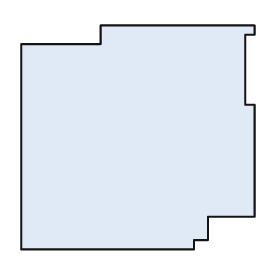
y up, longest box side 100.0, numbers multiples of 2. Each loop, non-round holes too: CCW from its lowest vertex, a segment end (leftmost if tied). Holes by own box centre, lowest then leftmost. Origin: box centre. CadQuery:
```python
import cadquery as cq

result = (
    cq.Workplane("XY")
    .moveTo(-50.0, -48.0)
    .lineTo(24.0, -48.0)
    .lineTo(24.0, -44.0)
    .lineTo(30.0, -44.0)
    .lineTo(30.0, -34.0)
    .lineTo(50.0, -34.0)
    .lineTo(50.0, 14.0)
    .lineTo(46.0, 14.0)
    .lineTo(46.0, 44.0)
    .lineTo(50.0, 44.0)
    .lineTo(50.0, 48.0)
    .lineTo(-16.0, 48.0)
    .lineTo(-16.0, 40.0)
    .lineTo(-50.0, 40.0)
    .close()
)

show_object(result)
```